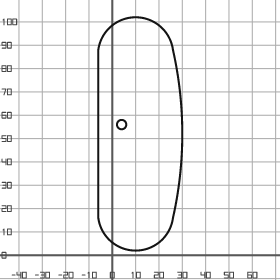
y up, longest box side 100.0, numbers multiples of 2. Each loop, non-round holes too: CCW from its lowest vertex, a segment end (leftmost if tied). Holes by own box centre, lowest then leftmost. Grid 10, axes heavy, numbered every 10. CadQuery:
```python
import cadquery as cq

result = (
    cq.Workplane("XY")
    .moveTo(-6.0, 16.0)
    .threePointArc((10.0, 2.0), (26.0, 16.0))
    .threePointArc((30.0, 52.0), (26.0, 88.0))
    .threePointArc((10.0, 102.0), (-6.0, 88.0))
    .close()
    .moveTo(4.0, 56.0)
    .circle(2.0)
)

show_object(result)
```